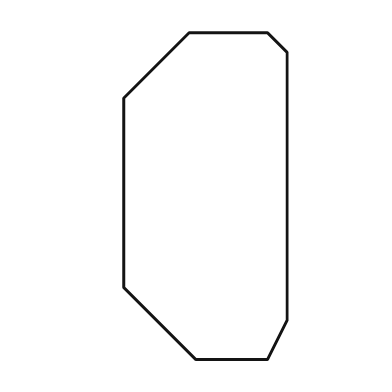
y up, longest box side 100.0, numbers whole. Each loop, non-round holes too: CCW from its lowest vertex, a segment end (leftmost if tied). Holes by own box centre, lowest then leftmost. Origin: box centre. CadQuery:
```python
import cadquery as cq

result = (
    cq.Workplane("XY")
    .moveTo(-3.0, -50.0)
    .lineTo(19.0, -50.0)
    .lineTo(25.0, -38.0)
    .lineTo(25.0, 44.0)
    .lineTo(19.0, 50.0)
    .lineTo(-5.0, 50.0)
    .lineTo(-25.0, 30.0)
    .lineTo(-25.0, -28.0)
    .close()
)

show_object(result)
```